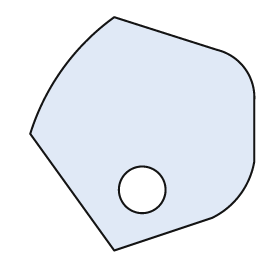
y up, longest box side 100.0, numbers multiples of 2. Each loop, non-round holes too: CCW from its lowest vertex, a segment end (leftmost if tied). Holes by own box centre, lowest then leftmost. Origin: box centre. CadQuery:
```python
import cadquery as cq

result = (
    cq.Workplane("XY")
    .moveTo(-12.0, -50.0)
    .lineTo(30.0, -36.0)
    .threePointArc((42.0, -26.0), (48.0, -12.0))
    .lineTo(48.0, 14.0)
    .threePointArc((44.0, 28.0), (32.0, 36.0))
    .lineTo(-12.0, 50.0)
    .threePointArc((-34.0, 28.0), (-48.0, 0.0))
    .close()
    .moveTo(0.0, -24.0)
    .circle(10.0)
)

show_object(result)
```